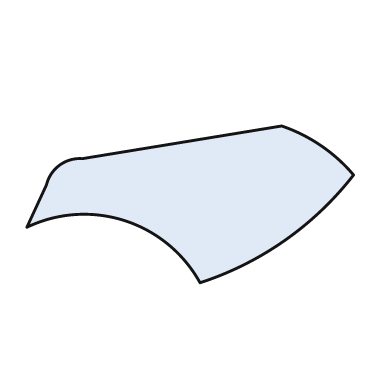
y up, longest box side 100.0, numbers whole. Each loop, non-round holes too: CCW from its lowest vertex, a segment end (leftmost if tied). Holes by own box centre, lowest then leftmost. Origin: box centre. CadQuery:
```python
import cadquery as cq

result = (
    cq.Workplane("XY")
    .moveTo(3.0, -24.0)
    .threePointArc((29.0, -11.0), (50.0, 9.0))
    .threePointArc((40.0, 18.0), (28.0, 24.0))
    .lineTo(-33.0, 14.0)
    .threePointArc((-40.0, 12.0), (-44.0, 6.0))
    .lineTo(-50.0, -7.0)
    .threePointArc((-20.0, -5.0), (3.0, -24.0))
    .close()
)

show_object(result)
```